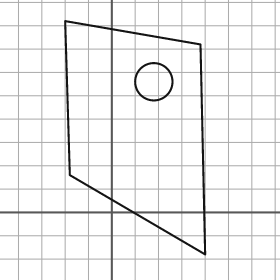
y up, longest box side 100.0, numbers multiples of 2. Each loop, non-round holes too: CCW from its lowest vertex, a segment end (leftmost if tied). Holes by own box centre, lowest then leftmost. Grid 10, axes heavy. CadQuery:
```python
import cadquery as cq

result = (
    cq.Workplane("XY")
    .moveTo(40.0, -18.0)
    .lineTo(38.0, 72.0)
    .lineTo(-20.0, 82.0)
    .lineTo(-18.0, 16.0)
    .close()
    .moveTo(18.0, 56.0)
    .circle(8.0)
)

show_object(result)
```